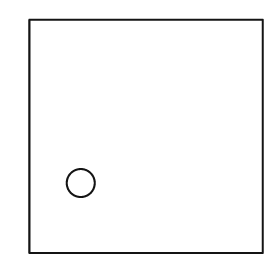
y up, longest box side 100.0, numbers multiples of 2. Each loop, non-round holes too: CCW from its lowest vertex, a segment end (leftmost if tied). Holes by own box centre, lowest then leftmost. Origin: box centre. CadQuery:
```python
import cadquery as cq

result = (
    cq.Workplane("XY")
    .moveTo(-50.0, -50.0)
    .lineTo(50.0, -50.0)
    .lineTo(50.0, 50.0)
    .lineTo(-50.0, 50.0)
    .close()
    .moveTo(-28.0, -20.0)
    .circle(6.0)
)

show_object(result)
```